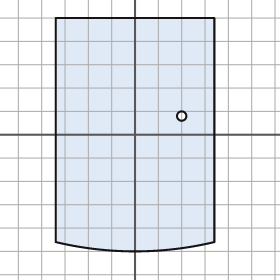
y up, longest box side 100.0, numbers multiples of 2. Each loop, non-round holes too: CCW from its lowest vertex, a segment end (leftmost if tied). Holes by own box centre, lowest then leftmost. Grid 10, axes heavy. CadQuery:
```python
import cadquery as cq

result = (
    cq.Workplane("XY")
    .moveTo(-34.0, -46.0)
    .threePointArc((0.0, -50.0), (34.0, -46.0))
    .lineTo(34.0, 50.0)
    .lineTo(-34.0, 50.0)
    .close()
    .moveTo(20.0, 8.0)
    .circle(2.0)
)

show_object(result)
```